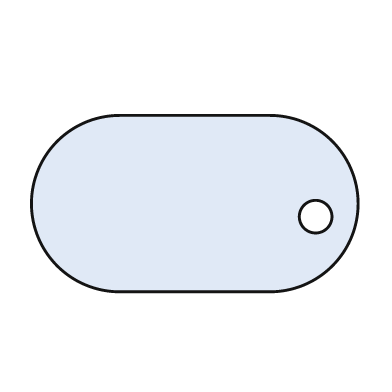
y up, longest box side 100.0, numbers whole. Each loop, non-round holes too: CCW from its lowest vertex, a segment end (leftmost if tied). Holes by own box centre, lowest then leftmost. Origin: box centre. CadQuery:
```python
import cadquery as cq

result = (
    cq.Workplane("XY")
    .moveTo(-23.0, -27.0)
    .lineTo(23.0, -27.0)
    .threePointArc((50.0, 0.0), (23.0, 27.0))
    .lineTo(-23.0, 27.0)
    .threePointArc((-50.0, 0.0), (-23.0, -27.0))
    .close()
    .moveTo(37.0, -4.0)
    .circle(5.0)
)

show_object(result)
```